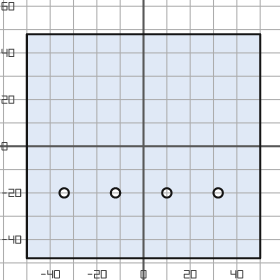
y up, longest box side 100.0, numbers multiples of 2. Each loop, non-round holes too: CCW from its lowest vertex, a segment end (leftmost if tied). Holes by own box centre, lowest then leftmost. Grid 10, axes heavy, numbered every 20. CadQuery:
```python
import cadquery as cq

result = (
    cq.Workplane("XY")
    .moveTo(-50.0, -48.0)
    .lineTo(50.0, -48.0)
    .lineTo(50.0, 48.0)
    .lineTo(-50.0, 48.0)
    .close()
    .moveTo(-34.0, -20.0)
    .circle(2.0)
    .moveTo(-12.0, -20.0)
    .circle(2.0)
    .moveTo(10.0, -20.0)
    .circle(2.0)
    .moveTo(32.0, -20.0)
    .circle(2.0)
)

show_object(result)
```